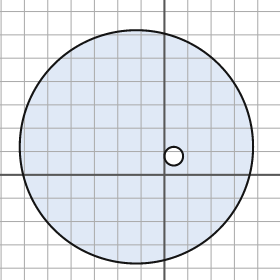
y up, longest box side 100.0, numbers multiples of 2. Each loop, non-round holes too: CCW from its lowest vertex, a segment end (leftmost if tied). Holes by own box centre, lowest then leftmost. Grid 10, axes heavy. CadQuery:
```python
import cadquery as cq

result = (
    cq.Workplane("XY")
    .moveTo(-12.0, 12.0)
    .circle(50.0)
    .moveTo(4.0, 8.0)
    .circle(4.0)
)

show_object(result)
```